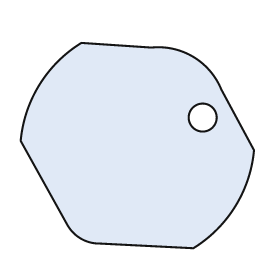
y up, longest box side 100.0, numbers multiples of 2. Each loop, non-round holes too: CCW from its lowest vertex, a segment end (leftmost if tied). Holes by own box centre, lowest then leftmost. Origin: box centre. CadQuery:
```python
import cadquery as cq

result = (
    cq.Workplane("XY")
    .moveTo(24.0, -44.0)
    .threePointArc((42.0, -26.0), (50.0, -2.0))
    .lineTo(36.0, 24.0)
    .threePointArc((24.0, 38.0), (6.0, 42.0))
    .lineTo(-24.0, 44.0)
    .threePointArc((-42.0, 26.0), (-50.0, 2.0))
    .lineTo(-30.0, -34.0)
    .threePointArc((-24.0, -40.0), (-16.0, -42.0))
    .close()
    .moveTo(28.0, 12.0)
    .circle(6.0)
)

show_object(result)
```